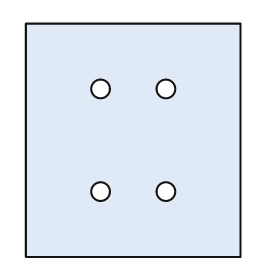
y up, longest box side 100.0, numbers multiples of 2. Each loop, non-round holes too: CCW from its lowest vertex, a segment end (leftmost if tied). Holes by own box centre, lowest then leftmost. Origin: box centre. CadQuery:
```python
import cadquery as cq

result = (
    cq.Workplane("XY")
    .moveTo(-46.0, -50.0)
    .lineTo(46.0, -50.0)
    .lineTo(46.0, 50.0)
    .lineTo(-46.0, 50.0)
    .close()
    .moveTo(-14.0, -22.0)
    .circle(4.0)
    .moveTo(14.0, -22.0)
    .circle(4.0)
    .moveTo(-14.0, 22.0)
    .circle(4.0)
    .moveTo(14.0, 22.0)
    .circle(4.0)
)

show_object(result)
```